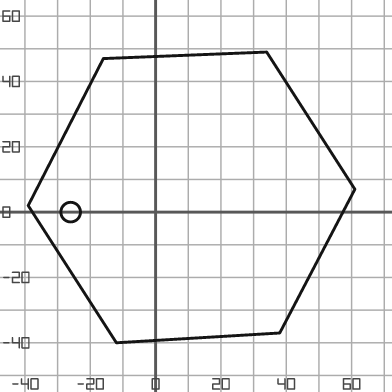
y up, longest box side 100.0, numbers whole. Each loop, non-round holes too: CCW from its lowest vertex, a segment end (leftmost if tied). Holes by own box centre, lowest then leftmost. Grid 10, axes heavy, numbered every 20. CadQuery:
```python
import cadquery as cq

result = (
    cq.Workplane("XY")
    .moveTo(-12.0, -40.0)
    .lineTo(38.0, -37.0)
    .lineTo(61.0, 7.0)
    .lineTo(34.0, 49.0)
    .lineTo(-16.0, 47.0)
    .lineTo(-39.0, 2.0)
    .close()
    .moveTo(-26.0, 0.0)
    .circle(3.0)
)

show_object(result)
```